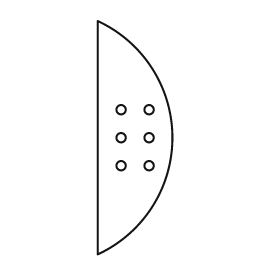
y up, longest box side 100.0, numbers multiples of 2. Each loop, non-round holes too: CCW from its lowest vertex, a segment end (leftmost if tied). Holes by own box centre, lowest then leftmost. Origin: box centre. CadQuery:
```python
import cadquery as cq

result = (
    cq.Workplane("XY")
    .moveTo(-16.0, -50.0)
    .threePointArc((16.0, 0.0), (-16.0, 50.0))
    .close()
    .moveTo(-6.0, -12.0)
    .circle(2.0)
    .moveTo(6.0, -12.0)
    .circle(2.0)
    .moveTo(-6.0, 0.0)
    .circle(2.0)
    .moveTo(6.0, 0.0)
    .circle(2.0)
    .moveTo(-6.0, 12.0)
    .circle(2.0)
    .moveTo(6.0, 12.0)
    .circle(2.0)
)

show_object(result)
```